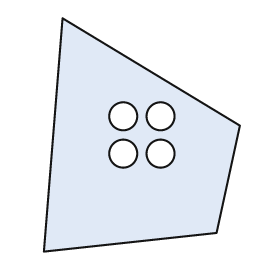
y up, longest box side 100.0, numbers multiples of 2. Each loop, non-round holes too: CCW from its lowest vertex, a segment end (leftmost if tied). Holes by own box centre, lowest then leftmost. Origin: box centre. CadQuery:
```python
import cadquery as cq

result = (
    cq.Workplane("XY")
    .moveTo(-42.0, -50.0)
    .lineTo(32.0, -42.0)
    .lineTo(42.0, 4.0)
    .lineTo(-34.0, 50.0)
    .close()
    .moveTo(-8.0, -8.0)
    .circle(6.0)
    .moveTo(8.0, -8.0)
    .circle(6.0)
    .moveTo(-8.0, 8.0)
    .circle(6.0)
    .moveTo(8.0, 8.0)
    .circle(6.0)
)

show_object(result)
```